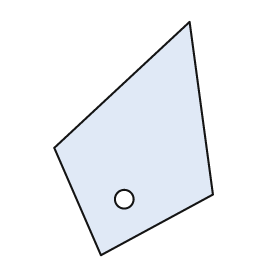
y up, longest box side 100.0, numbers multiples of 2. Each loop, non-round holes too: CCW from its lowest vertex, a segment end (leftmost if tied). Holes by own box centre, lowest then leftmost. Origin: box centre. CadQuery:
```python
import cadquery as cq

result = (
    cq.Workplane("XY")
    .moveTo(-14.0, -50.0)
    .lineTo(34.0, -24.0)
    .lineTo(24.0, 50.0)
    .lineTo(-34.0, -4.0)
    .close()
    .moveTo(-4.0, -26.0)
    .circle(4.0)
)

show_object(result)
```